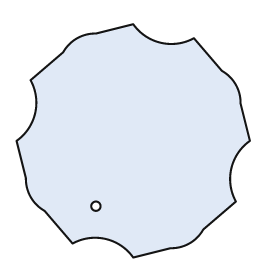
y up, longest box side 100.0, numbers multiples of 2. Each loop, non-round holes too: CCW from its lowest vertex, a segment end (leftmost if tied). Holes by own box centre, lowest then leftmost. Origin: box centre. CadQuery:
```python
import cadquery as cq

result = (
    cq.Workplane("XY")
    .moveTo(0.0, -50.0)
    .lineTo(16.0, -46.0)
    .threePointArc((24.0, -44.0), (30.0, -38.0))
    .lineTo(44.0, -26.0)
    .threePointArc((42.0, -12.0), (50.0, 0.0))
    .lineTo(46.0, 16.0)
    .threePointArc((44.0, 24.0), (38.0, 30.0))
    .lineTo(26.0, 44.0)
    .threePointArc((12.0, 42.0), (0.0, 50.0))
    .lineTo(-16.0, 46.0)
    .threePointArc((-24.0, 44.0), (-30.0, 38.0))
    .lineTo(-44.0, 26.0)
    .threePointArc((-42.0, 12.0), (-50.0, 0.0))
    .lineTo(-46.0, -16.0)
    .threePointArc((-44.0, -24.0), (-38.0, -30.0))
    .lineTo(-26.0, -44.0)
    .threePointArc((-12.0, -42.0), (0.0, -50.0))
    .close()
    .moveTo(-16.0, -28.0)
    .circle(2.0)
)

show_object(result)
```